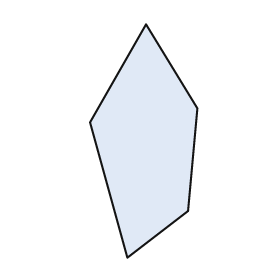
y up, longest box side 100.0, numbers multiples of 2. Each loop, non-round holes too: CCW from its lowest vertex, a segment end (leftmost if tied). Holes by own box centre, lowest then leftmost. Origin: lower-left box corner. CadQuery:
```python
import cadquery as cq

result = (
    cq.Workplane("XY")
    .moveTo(16.0, 0.0)
    .lineTo(42.0, 20.0)
    .lineTo(46.0, 64.0)
    .lineTo(24.0, 100.0)
    .lineTo(0.0, 58.0)
    .close()
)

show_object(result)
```